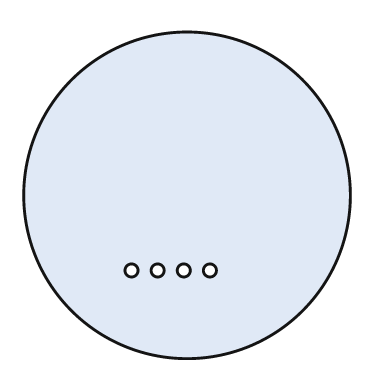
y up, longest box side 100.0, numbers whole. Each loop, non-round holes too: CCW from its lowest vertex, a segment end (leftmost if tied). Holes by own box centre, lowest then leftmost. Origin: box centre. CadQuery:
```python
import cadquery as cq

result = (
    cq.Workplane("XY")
    .moveTo(0.0, 0.0)
    .circle(50.0)
    .moveTo(-17.0, -23.0)
    .circle(2.0)
    .moveTo(-9.0, -23.0)
    .circle(2.0)
    .moveTo(-1.0, -23.0)
    .circle(2.0)
    .moveTo(7.0, -23.0)
    .circle(2.0)
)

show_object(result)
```